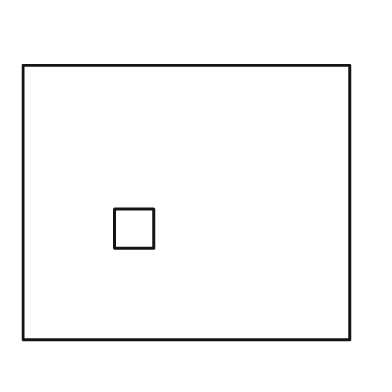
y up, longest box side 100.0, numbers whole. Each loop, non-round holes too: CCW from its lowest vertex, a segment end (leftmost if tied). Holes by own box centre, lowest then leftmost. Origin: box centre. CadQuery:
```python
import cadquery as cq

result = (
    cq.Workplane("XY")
    .moveTo(-50.0, -42.0)
    .lineTo(50.0, -42.0)
    .lineTo(50.0, 42.0)
    .lineTo(-50.0, 42.0)
    .close()
    .moveTo(-22.0, -14.0)
    .lineTo(-10.0, -14.0)
    .lineTo(-10.0, -2.0)
    .lineTo(-22.0, -2.0)
    .close()
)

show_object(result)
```